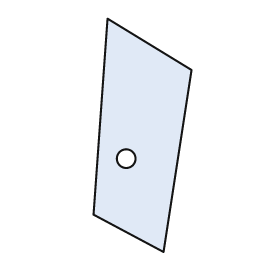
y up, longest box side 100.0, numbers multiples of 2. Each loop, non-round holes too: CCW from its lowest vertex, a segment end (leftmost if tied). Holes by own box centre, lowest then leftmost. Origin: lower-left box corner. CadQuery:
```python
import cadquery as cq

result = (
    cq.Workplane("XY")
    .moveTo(30.0, 0.0)
    .lineTo(42.0, 78.0)
    .lineTo(6.0, 100.0)
    .lineTo(0.0, 16.0)
    .close()
    .moveTo(14.0, 40.0)
    .circle(4.0)
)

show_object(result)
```